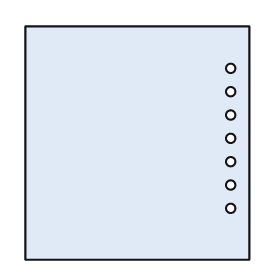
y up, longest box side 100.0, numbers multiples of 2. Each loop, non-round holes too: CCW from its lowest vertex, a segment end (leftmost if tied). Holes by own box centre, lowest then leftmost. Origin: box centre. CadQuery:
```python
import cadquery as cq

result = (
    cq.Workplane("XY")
    .moveTo(-48.0, -50.0)
    .lineTo(48.0, -50.0)
    .lineTo(48.0, 50.0)
    .lineTo(-48.0, 50.0)
    .close()
    .moveTo(40.0, -28.0)
    .circle(2.0)
    .moveTo(40.0, -18.0)
    .circle(2.0)
    .moveTo(40.0, -8.0)
    .circle(2.0)
    .moveTo(40.0, 2.0)
    .circle(2.0)
    .moveTo(40.0, 12.0)
    .circle(2.0)
    .moveTo(40.0, 22.0)
    .circle(2.0)
    .moveTo(40.0, 32.0)
    .circle(2.0)
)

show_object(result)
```